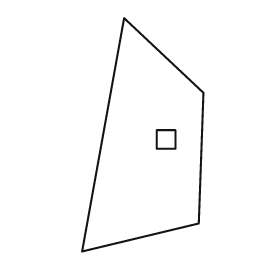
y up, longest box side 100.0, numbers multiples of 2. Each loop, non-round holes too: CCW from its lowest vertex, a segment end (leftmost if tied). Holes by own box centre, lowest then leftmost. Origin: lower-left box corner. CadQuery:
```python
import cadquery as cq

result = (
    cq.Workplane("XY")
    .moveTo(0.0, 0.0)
    .lineTo(50.0, 12.0)
    .lineTo(52.0, 68.0)
    .lineTo(18.0, 100.0)
    .close()
    .moveTo(32.0, 44.0)
    .lineTo(40.0, 44.0)
    .lineTo(40.0, 52.0)
    .lineTo(32.0, 52.0)
    .close()
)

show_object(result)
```